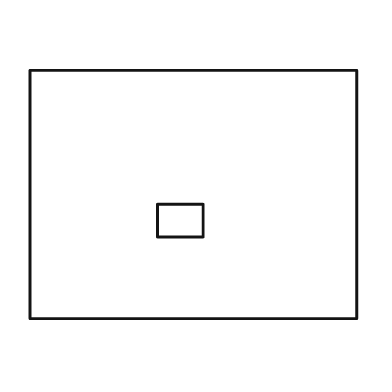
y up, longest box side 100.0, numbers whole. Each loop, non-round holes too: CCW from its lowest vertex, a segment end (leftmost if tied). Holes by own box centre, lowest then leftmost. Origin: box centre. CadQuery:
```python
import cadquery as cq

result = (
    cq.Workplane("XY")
    .moveTo(-50.0, -38.0)
    .lineTo(50.0, -38.0)
    .lineTo(50.0, 38.0)
    .lineTo(-50.0, 38.0)
    .close()
    .moveTo(-11.0, -13.0)
    .lineTo(3.0, -13.0)
    .lineTo(3.0, -3.0)
    .lineTo(-11.0, -3.0)
    .close()
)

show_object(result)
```